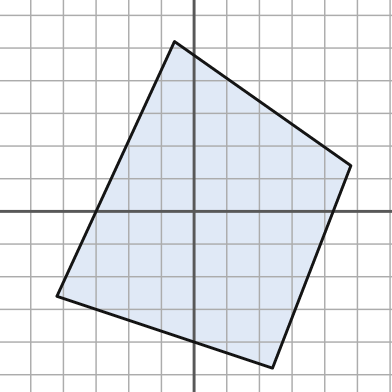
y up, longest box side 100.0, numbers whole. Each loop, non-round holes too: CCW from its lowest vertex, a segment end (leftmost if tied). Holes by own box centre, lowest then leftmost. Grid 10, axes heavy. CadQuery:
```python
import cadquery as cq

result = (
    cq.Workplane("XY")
    .moveTo(24.0, -48.0)
    .lineTo(48.0, 14.0)
    .lineTo(-6.0, 52.0)
    .lineTo(-42.0, -26.0)
    .close()
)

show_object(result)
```